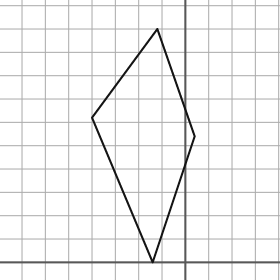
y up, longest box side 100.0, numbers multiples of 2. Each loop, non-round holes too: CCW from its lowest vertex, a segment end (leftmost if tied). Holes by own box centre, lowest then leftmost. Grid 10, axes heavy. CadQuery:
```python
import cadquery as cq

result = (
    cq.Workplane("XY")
    .moveTo(-14.0, 0.0)
    .lineTo(4.0, 54.0)
    .lineTo(-12.0, 100.0)
    .lineTo(-40.0, 62.0)
    .close()
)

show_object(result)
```